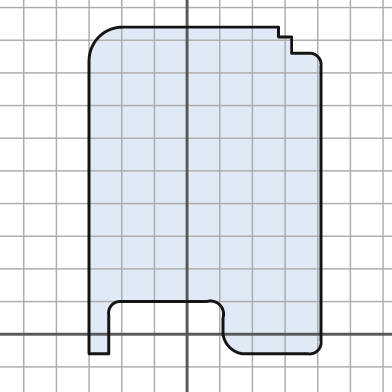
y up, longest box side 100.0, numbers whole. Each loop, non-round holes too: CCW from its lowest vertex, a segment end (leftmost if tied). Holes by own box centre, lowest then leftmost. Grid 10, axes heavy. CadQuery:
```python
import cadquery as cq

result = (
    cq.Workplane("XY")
    .moveTo(-30.0, -6.0)
    .lineTo(-24.0, -6.0)
    .lineTo(-24.0, 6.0)
    .threePointArc((-23.0, 9.0), (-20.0, 10.0))
    .lineTo(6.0, 10.0)
    .threePointArc((10.0, 9.0), (11.0, 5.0))
    .lineTo(11.0, 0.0)
    .threePointArc((13.0, -4.0), (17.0, -6.0))
    .lineTo(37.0, -6.0)
    .threePointArc((40.0, -5.0), (41.0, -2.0))
    .lineTo(41.0, 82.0)
    .threePointArc((40.0, 85.0), (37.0, 86.0))
    .lineTo(32.0, 86.0)
    .lineTo(32.0, 91.0)
    .lineTo(28.0, 91.0)
    .lineTo(28.0, 94.0)
    .lineTo(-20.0, 94.0)
    .threePointArc((-27.0, 91.0), (-30.0, 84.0))
    .close()
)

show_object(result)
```